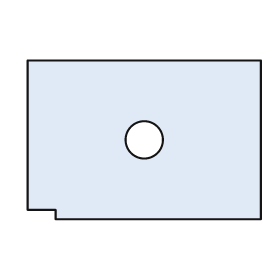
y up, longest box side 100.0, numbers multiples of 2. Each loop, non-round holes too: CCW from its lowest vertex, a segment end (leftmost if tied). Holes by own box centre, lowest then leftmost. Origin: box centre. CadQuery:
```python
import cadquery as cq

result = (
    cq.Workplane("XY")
    .moveTo(-38.0, -34.0)
    .lineTo(50.0, -34.0)
    .lineTo(50.0, 34.0)
    .lineTo(-50.0, 34.0)
    .lineTo(-50.0, -30.0)
    .lineTo(-38.0, -30.0)
    .close()
    .moveTo(0.0, 0.0)
    .circle(8.0)
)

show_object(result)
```